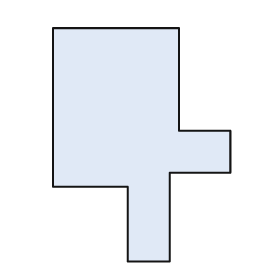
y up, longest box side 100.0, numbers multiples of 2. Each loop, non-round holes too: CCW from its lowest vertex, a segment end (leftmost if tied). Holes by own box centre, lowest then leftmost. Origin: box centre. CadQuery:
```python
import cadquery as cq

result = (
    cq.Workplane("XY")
    .moveTo(-6.0, -50.0)
    .lineTo(12.0, -50.0)
    .lineTo(12.0, -12.0)
    .lineTo(38.0, -12.0)
    .lineTo(38.0, 6.0)
    .lineTo(16.0, 6.0)
    .lineTo(16.0, 50.0)
    .lineTo(-38.0, 50.0)
    .lineTo(-38.0, -18.0)
    .lineTo(-6.0, -18.0)
    .close()
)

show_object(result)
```